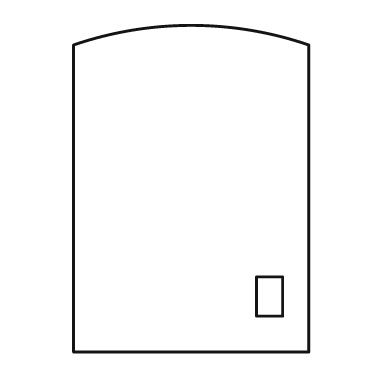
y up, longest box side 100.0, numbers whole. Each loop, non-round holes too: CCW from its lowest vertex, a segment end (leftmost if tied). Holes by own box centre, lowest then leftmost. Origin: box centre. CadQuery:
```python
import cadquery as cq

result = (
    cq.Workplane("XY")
    .moveTo(-36.0, -50.0)
    .lineTo(36.0, -50.0)
    .lineTo(36.0, 44.0)
    .threePointArc((0.0, 50.0), (-36.0, 44.0))
    .close()
    .moveTo(20.0, -39.0)
    .lineTo(28.0, -39.0)
    .lineTo(28.0, -27.0)
    .lineTo(20.0, -27.0)
    .close()
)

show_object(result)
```